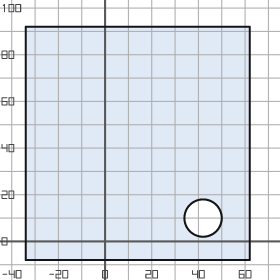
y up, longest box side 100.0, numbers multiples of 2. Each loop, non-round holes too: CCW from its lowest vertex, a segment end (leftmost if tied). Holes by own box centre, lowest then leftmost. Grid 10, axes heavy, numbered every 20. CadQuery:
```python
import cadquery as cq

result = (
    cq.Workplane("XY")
    .moveTo(-34.0, -8.0)
    .lineTo(62.0, -8.0)
    .lineTo(62.0, 92.0)
    .lineTo(-34.0, 92.0)
    .close()
    .moveTo(42.0, 10.0)
    .circle(8.0)
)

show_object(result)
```